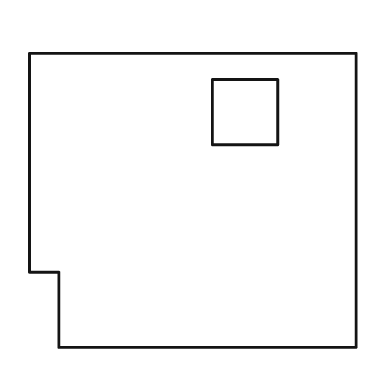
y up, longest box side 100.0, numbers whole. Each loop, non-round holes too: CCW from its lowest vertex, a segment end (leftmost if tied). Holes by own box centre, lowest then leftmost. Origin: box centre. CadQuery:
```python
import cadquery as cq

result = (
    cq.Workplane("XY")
    .moveTo(-41.0, -45.0)
    .lineTo(50.0, -45.0)
    .lineTo(50.0, 45.0)
    .lineTo(-50.0, 45.0)
    .lineTo(-50.0, -22.0)
    .lineTo(-41.0, -22.0)
    .close()
    .moveTo(6.0, 17.0)
    .lineTo(26.0, 17.0)
    .lineTo(26.0, 37.0)
    .lineTo(6.0, 37.0)
    .close()
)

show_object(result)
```